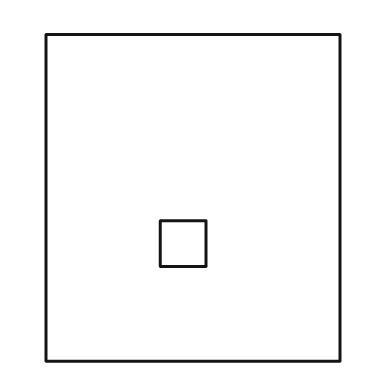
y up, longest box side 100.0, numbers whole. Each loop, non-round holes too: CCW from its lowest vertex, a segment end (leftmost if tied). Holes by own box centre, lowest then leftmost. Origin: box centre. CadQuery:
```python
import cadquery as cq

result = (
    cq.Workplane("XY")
    .moveTo(-45.0, -50.0)
    .lineTo(45.0, -50.0)
    .lineTo(45.0, 50.0)
    .lineTo(-45.0, 50.0)
    .close()
    .moveTo(-10.0, -21.0)
    .lineTo(4.0, -21.0)
    .lineTo(4.0, -7.0)
    .lineTo(-10.0, -7.0)
    .close()
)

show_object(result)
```